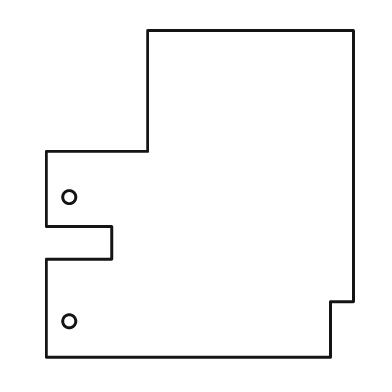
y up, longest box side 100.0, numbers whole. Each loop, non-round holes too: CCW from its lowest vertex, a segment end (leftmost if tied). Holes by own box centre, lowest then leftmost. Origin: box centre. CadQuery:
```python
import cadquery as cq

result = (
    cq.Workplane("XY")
    .moveTo(-47.0, -50.0)
    .lineTo(40.0, -50.0)
    .lineTo(40.0, -33.0)
    .lineTo(47.0, -33.0)
    .lineTo(47.0, 50.0)
    .lineTo(-16.0, 50.0)
    .lineTo(-16.0, 13.0)
    .lineTo(-47.0, 13.0)
    .lineTo(-47.0, -10.0)
    .lineTo(-27.0, -10.0)
    .lineTo(-27.0, -20.0)
    .lineTo(-47.0, -20.0)
    .close()
    .moveTo(-40.0, -39.0)
    .circle(2.0)
    .moveTo(-40.0, -1.0)
    .circle(2.0)
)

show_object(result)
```